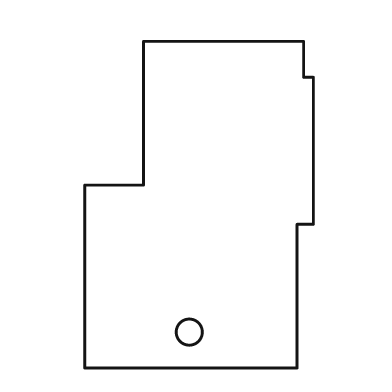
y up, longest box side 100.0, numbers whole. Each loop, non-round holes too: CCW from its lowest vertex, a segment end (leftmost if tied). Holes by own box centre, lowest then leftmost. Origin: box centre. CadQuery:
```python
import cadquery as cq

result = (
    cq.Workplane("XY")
    .moveTo(-35.0, -50.0)
    .lineTo(30.0, -50.0)
    .lineTo(30.0, -6.0)
    .lineTo(35.0, -6.0)
    .lineTo(35.0, 39.0)
    .lineTo(32.0, 39.0)
    .lineTo(32.0, 50.0)
    .lineTo(-17.0, 50.0)
    .lineTo(-17.0, 6.0)
    .lineTo(-35.0, 6.0)
    .close()
    .moveTo(-3.0, -39.0)
    .circle(4.0)
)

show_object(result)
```